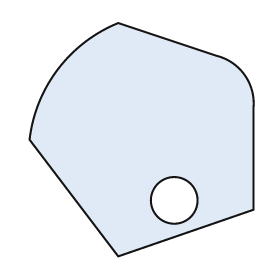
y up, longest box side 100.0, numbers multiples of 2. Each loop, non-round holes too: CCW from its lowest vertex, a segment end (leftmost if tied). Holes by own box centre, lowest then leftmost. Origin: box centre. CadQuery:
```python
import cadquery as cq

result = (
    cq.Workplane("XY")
    .moveTo(-10.0, -50.0)
    .lineTo(48.0, -30.0)
    .lineTo(48.0, 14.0)
    .threePointArc((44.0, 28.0), (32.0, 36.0))
    .lineTo(-10.0, 50.0)
    .threePointArc((-36.0, 30.0), (-48.0, 0.0))
    .close()
    .moveTo(14.0, -26.0)
    .circle(10.0)
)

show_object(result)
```